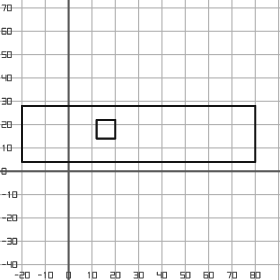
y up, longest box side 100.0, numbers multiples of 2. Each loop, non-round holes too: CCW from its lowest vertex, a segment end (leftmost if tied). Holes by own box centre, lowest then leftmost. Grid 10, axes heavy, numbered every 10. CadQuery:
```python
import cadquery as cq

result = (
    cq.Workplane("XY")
    .moveTo(-20.0, 4.0)
    .lineTo(80.0, 4.0)
    .lineTo(80.0, 28.0)
    .lineTo(-20.0, 28.0)
    .close()
    .moveTo(12.0, 14.0)
    .lineTo(20.0, 14.0)
    .lineTo(20.0, 22.0)
    .lineTo(12.0, 22.0)
    .close()
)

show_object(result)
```